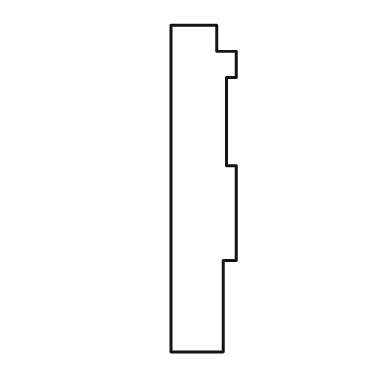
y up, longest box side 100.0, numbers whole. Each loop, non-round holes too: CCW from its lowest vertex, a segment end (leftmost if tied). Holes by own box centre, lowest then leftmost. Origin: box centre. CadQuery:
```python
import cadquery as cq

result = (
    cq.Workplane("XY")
    .moveTo(-10.0, -50.0)
    .lineTo(6.0, -50.0)
    .lineTo(6.0, -22.0)
    .lineTo(10.0, -22.0)
    .lineTo(10.0, 7.0)
    .lineTo(7.0, 7.0)
    .lineTo(7.0, 34.0)
    .lineTo(10.0, 34.0)
    .lineTo(10.0, 42.0)
    .lineTo(4.0, 42.0)
    .lineTo(4.0, 50.0)
    .lineTo(-10.0, 50.0)
    .close()
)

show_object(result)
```